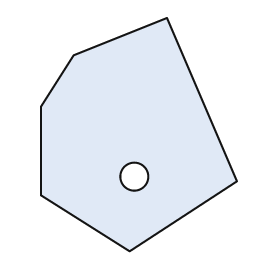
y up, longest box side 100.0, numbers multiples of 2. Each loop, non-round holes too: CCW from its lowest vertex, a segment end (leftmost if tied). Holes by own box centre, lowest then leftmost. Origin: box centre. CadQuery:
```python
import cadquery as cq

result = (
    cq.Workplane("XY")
    .moveTo(-4.0, -50.0)
    .lineTo(42.0, -20.0)
    .lineTo(12.0, 50.0)
    .lineTo(-28.0, 34.0)
    .lineTo(-42.0, 12.0)
    .lineTo(-42.0, -26.0)
    .close()
    .moveTo(-2.0, -18.0)
    .circle(6.0)
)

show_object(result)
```